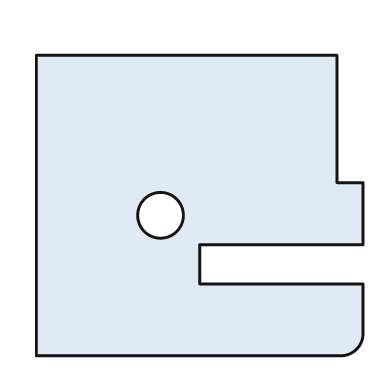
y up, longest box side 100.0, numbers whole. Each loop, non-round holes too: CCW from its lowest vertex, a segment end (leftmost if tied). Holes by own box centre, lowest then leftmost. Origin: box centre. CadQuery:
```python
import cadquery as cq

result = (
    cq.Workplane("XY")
    .moveTo(-50.0, -46.0)
    .lineTo(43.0, -46.0)
    .threePointArc((48.0, -44.0), (50.0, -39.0))
    .lineTo(50.0, -24.0)
    .lineTo(0.0, -24.0)
    .lineTo(0.0, -12.0)
    .lineTo(50.0, -12.0)
    .lineTo(50.0, 7.0)
    .lineTo(42.0, 7.0)
    .lineTo(42.0, 46.0)
    .lineTo(-50.0, 46.0)
    .close()
    .moveTo(-12.0, -3.0)
    .circle(7.0)
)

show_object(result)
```